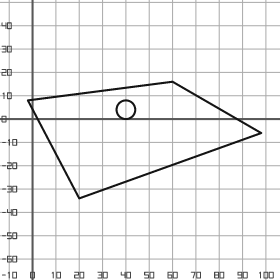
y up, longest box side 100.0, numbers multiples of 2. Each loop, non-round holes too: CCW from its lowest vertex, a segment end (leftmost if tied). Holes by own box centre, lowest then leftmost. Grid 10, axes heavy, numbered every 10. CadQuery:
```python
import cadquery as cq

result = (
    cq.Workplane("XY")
    .moveTo(20.0, -34.0)
    .lineTo(98.0, -6.0)
    .lineTo(60.0, 16.0)
    .lineTo(-2.0, 8.0)
    .close()
    .moveTo(40.0, 4.0)
    .circle(4.0)
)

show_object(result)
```